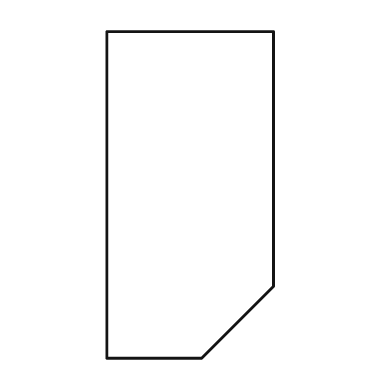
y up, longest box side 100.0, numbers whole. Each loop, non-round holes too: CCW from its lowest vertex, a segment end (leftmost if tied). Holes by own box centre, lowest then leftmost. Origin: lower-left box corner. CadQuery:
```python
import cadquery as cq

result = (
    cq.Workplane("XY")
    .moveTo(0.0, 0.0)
    .lineTo(29.0, 0.0)
    .lineTo(51.0, 22.0)
    .lineTo(51.0, 100.0)
    .lineTo(0.0, 100.0)
    .close()
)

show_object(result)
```